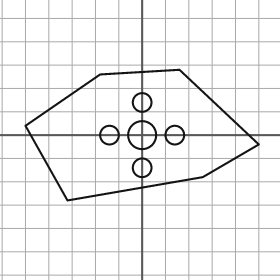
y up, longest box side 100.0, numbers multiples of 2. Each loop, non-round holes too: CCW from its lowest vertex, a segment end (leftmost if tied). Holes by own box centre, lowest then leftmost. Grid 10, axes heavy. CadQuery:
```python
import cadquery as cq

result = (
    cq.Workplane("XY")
    .moveTo(-32.0, -28.0)
    .lineTo(26.0, -18.0)
    .lineTo(50.0, -4.0)
    .lineTo(16.0, 28.0)
    .lineTo(-18.0, 26.0)
    .lineTo(-50.0, 4.0)
    .close()
    .moveTo(0.0, -14.0)
    .circle(4.0)
    .moveTo(-14.0, 0.0)
    .circle(4.0)
    .moveTo(0.0, 0.0)
    .circle(6.0)
    .moveTo(14.0, 0.0)
    .circle(4.0)
    .moveTo(0.0, 14.0)
    .circle(4.0)
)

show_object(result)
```